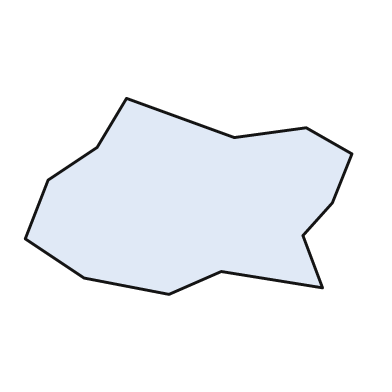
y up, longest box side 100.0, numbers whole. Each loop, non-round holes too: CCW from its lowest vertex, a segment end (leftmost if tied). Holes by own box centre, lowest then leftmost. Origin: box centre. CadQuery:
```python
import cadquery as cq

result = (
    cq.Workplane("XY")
    .moveTo(-6.0, -30.0)
    .lineTo(10.0, -23.0)
    .lineTo(41.0, -28.0)
    .lineTo(35.0, -12.0)
    .lineTo(44.0, -2.0)
    .lineTo(50.0, 13.0)
    .lineTo(36.0, 21.0)
    .lineTo(14.0, 18.0)
    .lineTo(-19.0, 30.0)
    .lineTo(-28.0, 15.0)
    .lineTo(-43.0, 5.0)
    .lineTo(-50.0, -13.0)
    .lineTo(-32.0, -25.0)
    .close()
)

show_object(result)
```